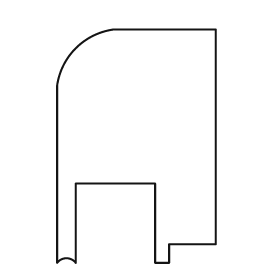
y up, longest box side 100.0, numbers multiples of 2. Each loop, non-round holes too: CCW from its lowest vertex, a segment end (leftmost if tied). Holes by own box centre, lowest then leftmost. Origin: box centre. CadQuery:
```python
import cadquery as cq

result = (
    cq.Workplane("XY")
    .moveTo(-34.0, -50.0)
    .threePointArc((-30.0, -48.0), (-26.0, -50.0))
    .lineTo(-26.0, -16.0)
    .lineTo(8.0, -16.0)
    .lineTo(8.0, -50.0)
    .lineTo(14.0, -50.0)
    .lineTo(14.0, -42.0)
    .lineTo(34.0, -42.0)
    .lineTo(34.0, 50.0)
    .lineTo(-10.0, 50.0)
    .threePointArc((-26.0, 42.0), (-34.0, 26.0))
    .close()
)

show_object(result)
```